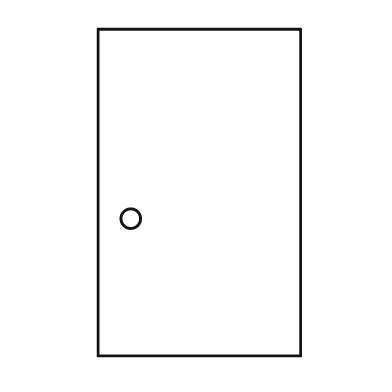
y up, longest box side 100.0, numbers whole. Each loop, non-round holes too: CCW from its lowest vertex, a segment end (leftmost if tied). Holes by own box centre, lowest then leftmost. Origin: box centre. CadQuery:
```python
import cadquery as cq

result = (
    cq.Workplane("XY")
    .moveTo(-31.0, -50.0)
    .lineTo(31.0, -50.0)
    .lineTo(31.0, 50.0)
    .lineTo(-31.0, 50.0)
    .close()
    .moveTo(-21.0, -8.0)
    .circle(3.0)
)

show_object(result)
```